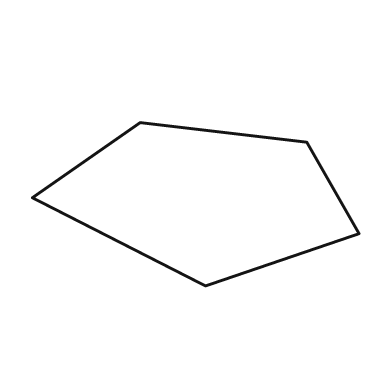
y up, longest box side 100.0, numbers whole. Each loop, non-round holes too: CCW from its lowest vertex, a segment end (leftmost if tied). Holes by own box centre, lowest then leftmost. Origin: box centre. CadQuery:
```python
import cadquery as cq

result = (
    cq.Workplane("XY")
    .moveTo(3.0, -25.0)
    .lineTo(50.0, -9.0)
    .lineTo(34.0, 19.0)
    .lineTo(-17.0, 25.0)
    .lineTo(-50.0, 2.0)
    .close()
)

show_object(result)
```